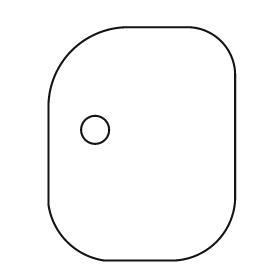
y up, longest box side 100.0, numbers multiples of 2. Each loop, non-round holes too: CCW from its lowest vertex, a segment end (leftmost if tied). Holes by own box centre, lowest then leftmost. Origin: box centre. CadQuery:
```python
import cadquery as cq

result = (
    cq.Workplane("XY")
    .moveTo(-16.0, -50.0)
    .lineTo(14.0, -50.0)
    .threePointArc((32.0, -42.0), (40.0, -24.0))
    .lineTo(40.0, 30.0)
    .threePointArc((34.0, 44.0), (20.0, 50.0))
    .lineTo(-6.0, 50.0)
    .threePointArc((-30.0, 40.0), (-40.0, 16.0))
    .lineTo(-40.0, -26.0)
    .threePointArc((-32.0, -42.0), (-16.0, -50.0))
    .close()
    .moveTo(-20.0, 6.0)
    .circle(6.0)
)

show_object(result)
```